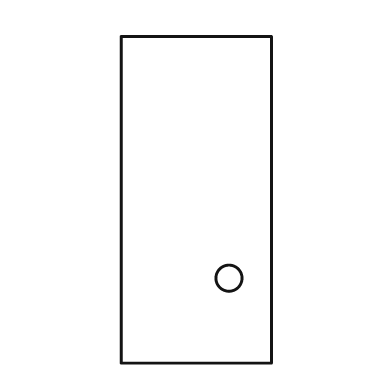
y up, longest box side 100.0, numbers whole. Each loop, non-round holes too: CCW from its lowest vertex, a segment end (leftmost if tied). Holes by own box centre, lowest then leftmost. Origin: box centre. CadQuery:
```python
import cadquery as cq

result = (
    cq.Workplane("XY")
    .moveTo(-23.0, -50.0)
    .lineTo(23.0, -50.0)
    .lineTo(23.0, 50.0)
    .lineTo(-23.0, 50.0)
    .close()
    .moveTo(10.0, -24.0)
    .circle(4.0)
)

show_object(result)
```